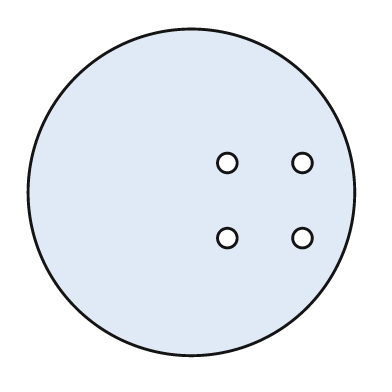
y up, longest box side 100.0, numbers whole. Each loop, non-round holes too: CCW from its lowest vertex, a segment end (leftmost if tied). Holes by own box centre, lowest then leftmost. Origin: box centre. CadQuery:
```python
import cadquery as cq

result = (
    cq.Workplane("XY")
    .moveTo(0.0, 0.0)
    .circle(50.0)
    .moveTo(11.0, -14.0)
    .circle(3.0)
    .moveTo(34.0, -14.0)
    .circle(3.0)
    .moveTo(11.0, 9.0)
    .circle(3.0)
    .moveTo(34.0, 9.0)
    .circle(3.0)
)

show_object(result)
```